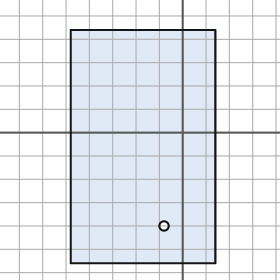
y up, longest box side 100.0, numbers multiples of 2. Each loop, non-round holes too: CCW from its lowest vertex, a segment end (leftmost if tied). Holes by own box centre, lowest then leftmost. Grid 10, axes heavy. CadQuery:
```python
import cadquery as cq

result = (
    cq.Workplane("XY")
    .moveTo(-48.0, -56.0)
    .lineTo(14.0, -56.0)
    .lineTo(14.0, 44.0)
    .lineTo(-48.0, 44.0)
    .close()
    .moveTo(-8.0, -40.0)
    .circle(2.0)
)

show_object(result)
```